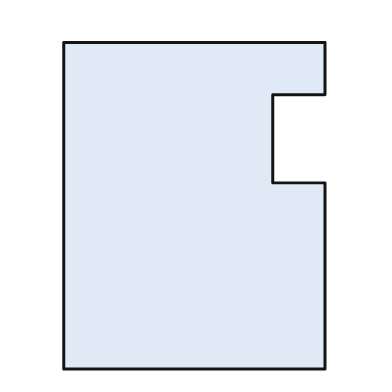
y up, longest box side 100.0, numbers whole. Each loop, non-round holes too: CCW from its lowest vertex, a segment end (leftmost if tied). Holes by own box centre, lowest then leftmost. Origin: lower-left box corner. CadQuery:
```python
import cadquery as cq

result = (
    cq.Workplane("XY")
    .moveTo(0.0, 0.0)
    .lineTo(80.0, 0.0)
    .lineTo(80.0, 57.0)
    .lineTo(64.0, 57.0)
    .lineTo(64.0, 84.0)
    .lineTo(80.0, 84.0)
    .lineTo(80.0, 100.0)
    .lineTo(0.0, 100.0)
    .close()
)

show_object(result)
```